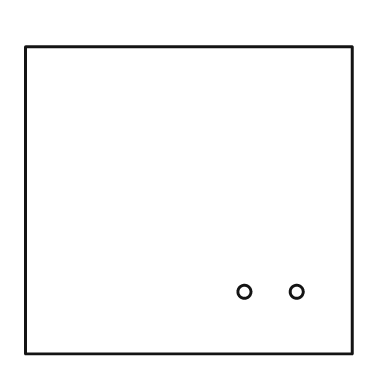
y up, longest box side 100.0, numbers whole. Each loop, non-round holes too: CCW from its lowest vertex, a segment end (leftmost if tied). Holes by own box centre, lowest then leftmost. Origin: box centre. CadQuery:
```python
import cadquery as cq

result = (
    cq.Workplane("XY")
    .moveTo(-50.0, -47.0)
    .lineTo(50.0, -47.0)
    .lineTo(50.0, 47.0)
    .lineTo(-50.0, 47.0)
    .close()
    .moveTo(17.0, -28.0)
    .circle(2.0)
    .moveTo(33.0, -28.0)
    .circle(2.0)
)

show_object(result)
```